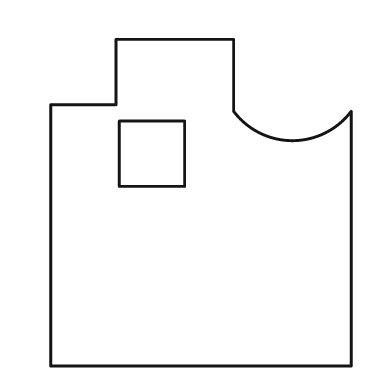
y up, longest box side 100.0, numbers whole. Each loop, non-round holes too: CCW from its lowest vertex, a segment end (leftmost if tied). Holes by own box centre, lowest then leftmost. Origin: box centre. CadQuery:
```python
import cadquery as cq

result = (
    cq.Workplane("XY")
    .moveTo(-46.0, -50.0)
    .lineTo(46.0, -50.0)
    .lineTo(46.0, 28.0)
    .threePointArc((28.0, 19.0), (10.0, 28.0))
    .lineTo(10.0, 50.0)
    .lineTo(-26.0, 50.0)
    .lineTo(-26.0, 30.0)
    .lineTo(-46.0, 30.0)
    .close()
    .moveTo(-25.0, 5.0)
    .lineTo(-5.0, 5.0)
    .lineTo(-5.0, 25.0)
    .lineTo(-25.0, 25.0)
    .close()
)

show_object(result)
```